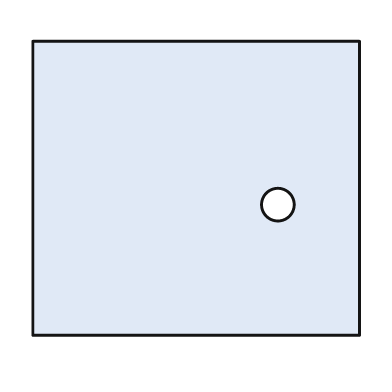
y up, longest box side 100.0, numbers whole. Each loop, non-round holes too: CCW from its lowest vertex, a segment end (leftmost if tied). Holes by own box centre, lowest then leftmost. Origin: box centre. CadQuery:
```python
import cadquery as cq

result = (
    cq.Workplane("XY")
    .moveTo(-50.0, -45.0)
    .lineTo(50.0, -45.0)
    .lineTo(50.0, 45.0)
    .lineTo(-50.0, 45.0)
    .close()
    .moveTo(25.0, -5.0)
    .circle(5.0)
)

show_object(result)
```